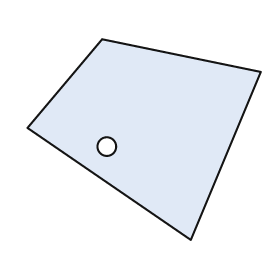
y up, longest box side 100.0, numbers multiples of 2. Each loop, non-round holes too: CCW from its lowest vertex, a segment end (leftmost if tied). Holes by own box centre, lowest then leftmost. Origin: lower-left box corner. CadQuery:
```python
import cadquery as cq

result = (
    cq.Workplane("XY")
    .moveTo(70.0, 0.0)
    .lineTo(100.0, 72.0)
    .lineTo(32.0, 86.0)
    .lineTo(0.0, 48.0)
    .close()
    .moveTo(34.0, 40.0)
    .circle(4.0)
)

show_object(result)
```